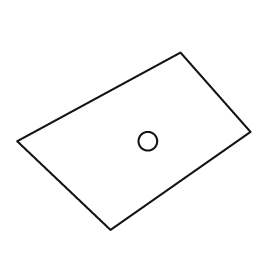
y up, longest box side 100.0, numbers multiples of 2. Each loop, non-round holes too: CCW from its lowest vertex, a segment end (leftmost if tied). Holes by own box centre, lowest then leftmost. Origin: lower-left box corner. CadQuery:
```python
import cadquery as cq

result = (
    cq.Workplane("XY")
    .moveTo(40.0, 0.0)
    .lineTo(100.0, 42.0)
    .lineTo(70.0, 76.0)
    .lineTo(0.0, 38.0)
    .close()
    .moveTo(56.0, 38.0)
    .circle(4.0)
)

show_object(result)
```